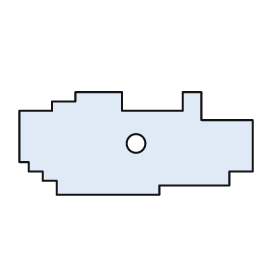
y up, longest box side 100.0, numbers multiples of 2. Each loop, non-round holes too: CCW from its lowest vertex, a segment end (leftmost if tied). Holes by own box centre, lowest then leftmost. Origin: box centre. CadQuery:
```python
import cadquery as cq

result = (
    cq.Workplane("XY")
    .moveTo(-34.0, -22.0)
    .lineTo(10.0, -22.0)
    .lineTo(10.0, -18.0)
    .lineTo(40.0, -18.0)
    .lineTo(40.0, -12.0)
    .lineTo(50.0, -12.0)
    .lineTo(50.0, 10.0)
    .lineTo(28.0, 10.0)
    .lineTo(28.0, 22.0)
    .lineTo(20.0, 22.0)
    .lineTo(20.0, 14.0)
    .lineTo(-6.0, 14.0)
    .lineTo(-6.0, 22.0)
    .lineTo(-26.0, 22.0)
    .lineTo(-26.0, 18.0)
    .lineTo(-36.0, 18.0)
    .lineTo(-36.0, 14.0)
    .lineTo(-50.0, 14.0)
    .lineTo(-50.0, -8.0)
    .lineTo(-46.0, -8.0)
    .lineTo(-46.0, -12.0)
    .lineTo(-40.0, -12.0)
    .lineTo(-40.0, -16.0)
    .lineTo(-34.0, -16.0)
    .close()
    .moveTo(0.0, 0.0)
    .circle(4.0)
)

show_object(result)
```